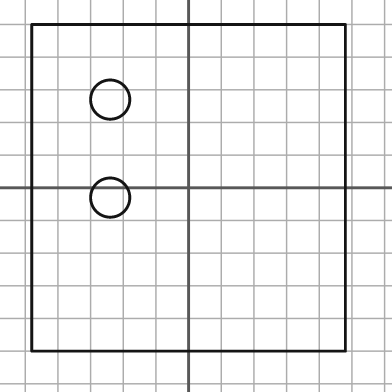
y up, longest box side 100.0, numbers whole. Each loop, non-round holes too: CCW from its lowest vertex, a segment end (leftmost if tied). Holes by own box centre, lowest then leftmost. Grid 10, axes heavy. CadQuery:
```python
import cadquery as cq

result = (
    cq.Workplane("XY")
    .moveTo(-48.0, -50.0)
    .lineTo(48.0, -50.0)
    .lineTo(48.0, 50.0)
    .lineTo(-48.0, 50.0)
    .close()
    .moveTo(-24.0, -3.0)
    .circle(6.0)
    .moveTo(-24.0, 27.0)
    .circle(6.0)
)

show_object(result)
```